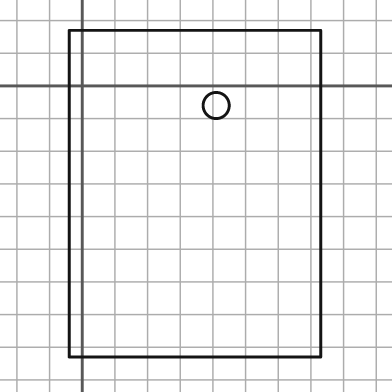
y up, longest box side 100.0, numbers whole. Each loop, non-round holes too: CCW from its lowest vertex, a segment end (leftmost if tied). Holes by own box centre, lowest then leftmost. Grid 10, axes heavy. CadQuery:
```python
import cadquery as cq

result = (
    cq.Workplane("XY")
    .moveTo(-4.0, -83.0)
    .lineTo(73.0, -83.0)
    .lineTo(73.0, 17.0)
    .lineTo(-4.0, 17.0)
    .close()
    .moveTo(41.0, -6.0)
    .circle(4.0)
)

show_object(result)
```